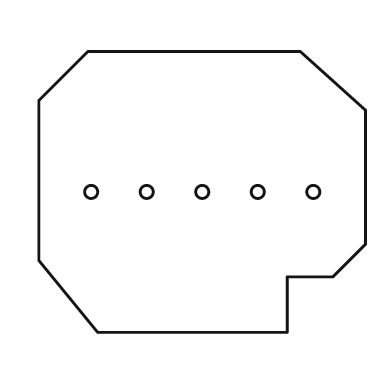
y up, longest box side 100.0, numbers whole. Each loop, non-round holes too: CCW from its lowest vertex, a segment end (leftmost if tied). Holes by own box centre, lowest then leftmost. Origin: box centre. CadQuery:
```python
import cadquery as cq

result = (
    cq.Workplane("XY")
    .moveTo(-32.0, -43.0)
    .lineTo(26.0, -43.0)
    .lineTo(26.0, -26.0)
    .lineTo(40.0, -26.0)
    .lineTo(50.0, -16.0)
    .lineTo(50.0, 25.0)
    .lineTo(30.0, 43.0)
    .lineTo(-35.0, 43.0)
    .lineTo(-50.0, 28.0)
    .lineTo(-50.0, -21.0)
    .close()
    .moveTo(-34.0, 0.0)
    .circle(2.0)
    .moveTo(-17.0, 0.0)
    .circle(2.0)
    .moveTo(0.0, 0.0)
    .circle(2.0)
    .moveTo(17.0, 0.0)
    .circle(2.0)
    .moveTo(34.0, 0.0)
    .circle(2.0)
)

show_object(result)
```